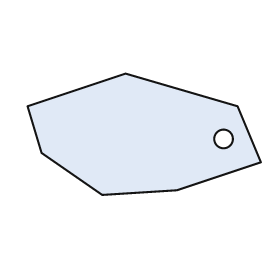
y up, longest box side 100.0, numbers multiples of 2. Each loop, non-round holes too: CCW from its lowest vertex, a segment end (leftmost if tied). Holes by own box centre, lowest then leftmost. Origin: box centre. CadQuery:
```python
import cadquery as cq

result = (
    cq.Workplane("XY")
    .moveTo(-18.0, -26.0)
    .lineTo(14.0, -24.0)
    .lineTo(50.0, -12.0)
    .lineTo(40.0, 12.0)
    .lineTo(-8.0, 26.0)
    .lineTo(-50.0, 12.0)
    .lineTo(-44.0, -8.0)
    .close()
    .moveTo(34.0, -2.0)
    .circle(4.0)
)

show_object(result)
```